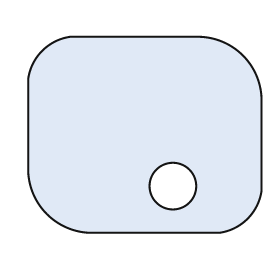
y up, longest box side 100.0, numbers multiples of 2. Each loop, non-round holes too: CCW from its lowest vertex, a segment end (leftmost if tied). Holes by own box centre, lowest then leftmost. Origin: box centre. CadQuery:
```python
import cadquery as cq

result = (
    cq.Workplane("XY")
    .moveTo(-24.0, -42.0)
    .lineTo(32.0, -42.0)
    .threePointArc((44.0, -36.0), (50.0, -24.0))
    .lineTo(50.0, 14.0)
    .threePointArc((42.0, 34.0), (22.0, 42.0))
    .lineTo(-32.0, 42.0)
    .threePointArc((-44.0, 36.0), (-50.0, 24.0))
    .lineTo(-50.0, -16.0)
    .threePointArc((-42.0, -34.0), (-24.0, -42.0))
    .close()
    .moveTo(12.0, -22.0)
    .circle(10.0)
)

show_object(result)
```